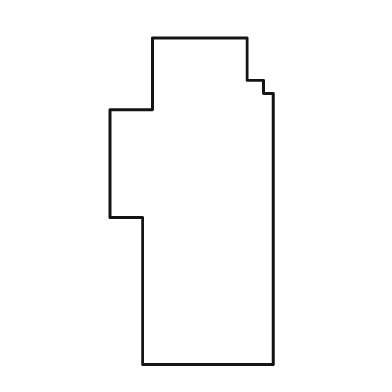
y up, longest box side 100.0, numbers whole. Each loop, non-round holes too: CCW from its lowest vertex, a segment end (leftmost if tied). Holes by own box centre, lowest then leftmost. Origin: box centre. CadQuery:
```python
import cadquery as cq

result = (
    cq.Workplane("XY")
    .moveTo(-15.0, -50.0)
    .lineTo(25.0, -50.0)
    .lineTo(25.0, 33.0)
    .lineTo(22.0, 33.0)
    .lineTo(22.0, 37.0)
    .lineTo(17.0, 37.0)
    .lineTo(17.0, 50.0)
    .lineTo(-12.0, 50.0)
    .lineTo(-12.0, 28.0)
    .lineTo(-25.0, 28.0)
    .lineTo(-25.0, -5.0)
    .lineTo(-15.0, -5.0)
    .close()
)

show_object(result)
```